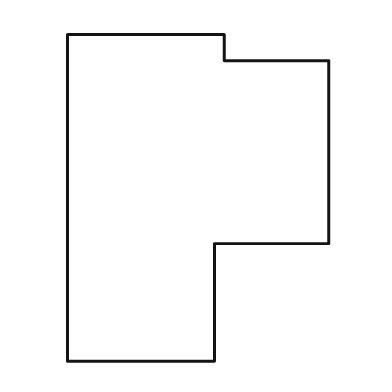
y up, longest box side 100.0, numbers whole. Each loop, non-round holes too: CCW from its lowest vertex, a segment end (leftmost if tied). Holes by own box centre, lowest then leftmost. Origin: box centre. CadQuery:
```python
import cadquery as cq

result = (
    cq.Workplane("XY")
    .moveTo(-40.0, -50.0)
    .lineTo(5.0, -50.0)
    .lineTo(5.0, -14.0)
    .lineTo(40.0, -14.0)
    .lineTo(40.0, 42.0)
    .lineTo(8.0, 42.0)
    .lineTo(8.0, 50.0)
    .lineTo(-40.0, 50.0)
    .close()
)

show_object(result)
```